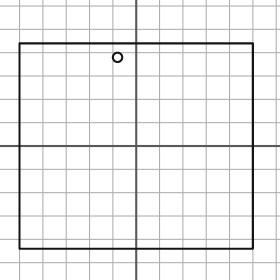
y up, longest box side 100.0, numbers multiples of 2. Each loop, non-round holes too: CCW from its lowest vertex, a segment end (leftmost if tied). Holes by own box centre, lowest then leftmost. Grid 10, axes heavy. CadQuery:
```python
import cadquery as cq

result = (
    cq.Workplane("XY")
    .moveTo(-50.0, -44.0)
    .lineTo(50.0, -44.0)
    .lineTo(50.0, 44.0)
    .lineTo(-50.0, 44.0)
    .close()
    .moveTo(-8.0, 38.0)
    .circle(2.0)
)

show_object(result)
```